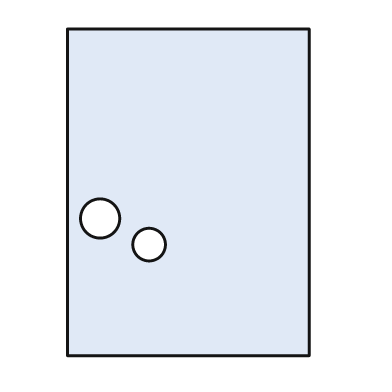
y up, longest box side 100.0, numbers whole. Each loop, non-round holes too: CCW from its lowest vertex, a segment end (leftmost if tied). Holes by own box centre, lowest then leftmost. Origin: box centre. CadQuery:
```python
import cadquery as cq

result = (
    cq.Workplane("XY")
    .moveTo(-37.0, -50.0)
    .lineTo(37.0, -50.0)
    .lineTo(37.0, 50.0)
    .lineTo(-37.0, 50.0)
    .close()
    .moveTo(-12.0, -16.0)
    .circle(5.0)
    .moveTo(-27.0, -8.0)
    .circle(6.0)
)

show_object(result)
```